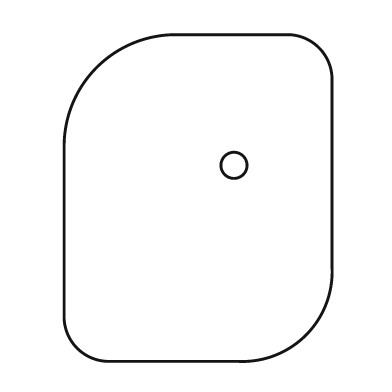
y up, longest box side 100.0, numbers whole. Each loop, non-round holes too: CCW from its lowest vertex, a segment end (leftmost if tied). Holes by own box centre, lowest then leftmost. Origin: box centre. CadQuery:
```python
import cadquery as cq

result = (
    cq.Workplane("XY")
    .moveTo(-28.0, -50.0)
    .lineTo(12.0, -50.0)
    .threePointArc((33.0, -42.0), (41.0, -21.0))
    .lineTo(41.0, 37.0)
    .threePointArc((37.0, 46.0), (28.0, 50.0))
    .lineTo(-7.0, 50.0)
    .threePointArc((-31.0, 40.0), (-41.0, 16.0))
    .lineTo(-41.0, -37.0)
    .threePointArc((-37.0, -46.0), (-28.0, -50.0))
    .close()
    .moveTo(11.0, 10.0)
    .circle(4.0)
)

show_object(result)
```